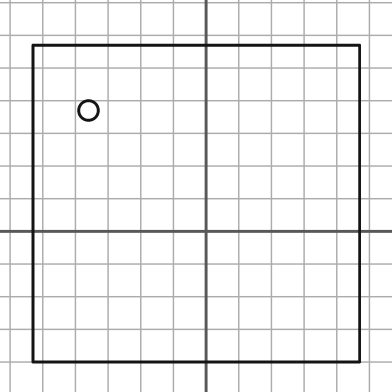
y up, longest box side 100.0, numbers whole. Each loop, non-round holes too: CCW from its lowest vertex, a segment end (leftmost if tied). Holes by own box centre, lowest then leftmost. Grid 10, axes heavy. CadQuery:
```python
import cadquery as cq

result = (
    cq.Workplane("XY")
    .moveTo(-53.0, -40.0)
    .lineTo(47.0, -40.0)
    .lineTo(47.0, 57.0)
    .lineTo(-53.0, 57.0)
    .close()
    .moveTo(-36.0, 37.0)
    .circle(3.0)
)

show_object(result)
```